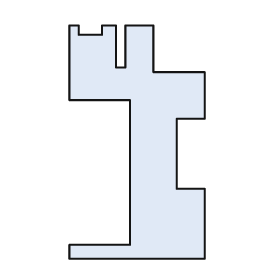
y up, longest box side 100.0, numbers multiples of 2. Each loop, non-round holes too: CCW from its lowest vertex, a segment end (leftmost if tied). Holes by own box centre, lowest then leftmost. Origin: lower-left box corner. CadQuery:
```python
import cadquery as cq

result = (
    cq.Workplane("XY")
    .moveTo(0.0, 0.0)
    .lineTo(58.0, 0.0)
    .lineTo(58.0, 30.0)
    .lineTo(46.0, 30.0)
    .lineTo(46.0, 60.0)
    .lineTo(58.0, 60.0)
    .lineTo(58.0, 80.0)
    .lineTo(36.0, 80.0)
    .lineTo(36.0, 100.0)
    .lineTo(24.0, 100.0)
    .lineTo(24.0, 82.0)
    .lineTo(20.0, 82.0)
    .lineTo(20.0, 100.0)
    .lineTo(14.0, 100.0)
    .lineTo(14.0, 96.0)
    .lineTo(4.0, 96.0)
    .lineTo(4.0, 100.0)
    .lineTo(0.0, 100.0)
    .lineTo(0.0, 68.0)
    .lineTo(26.0, 68.0)
    .lineTo(26.0, 6.0)
    .lineTo(0.0, 6.0)
    .close()
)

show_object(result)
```